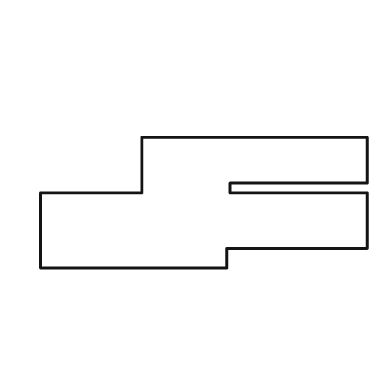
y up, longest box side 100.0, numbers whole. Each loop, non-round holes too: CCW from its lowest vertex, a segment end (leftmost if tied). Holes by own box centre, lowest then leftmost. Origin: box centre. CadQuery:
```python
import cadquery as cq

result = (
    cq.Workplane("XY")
    .moveTo(-50.0, -20.0)
    .lineTo(7.0, -20.0)
    .lineTo(7.0, -14.0)
    .lineTo(50.0, -14.0)
    .lineTo(50.0, 3.0)
    .lineTo(8.0, 3.0)
    .lineTo(8.0, 6.0)
    .lineTo(50.0, 6.0)
    .lineTo(50.0, 20.0)
    .lineTo(-19.0, 20.0)
    .lineTo(-19.0, 3.0)
    .lineTo(-50.0, 3.0)
    .close()
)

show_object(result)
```